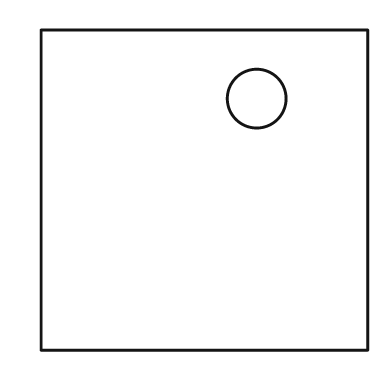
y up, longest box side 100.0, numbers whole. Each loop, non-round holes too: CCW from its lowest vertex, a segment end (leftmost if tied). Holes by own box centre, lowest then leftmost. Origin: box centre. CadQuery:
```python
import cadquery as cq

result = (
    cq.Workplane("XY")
    .moveTo(-50.0, -49.0)
    .lineTo(50.0, -49.0)
    .lineTo(50.0, 49.0)
    .lineTo(-50.0, 49.0)
    .close()
    .moveTo(16.0, 28.0)
    .circle(9.0)
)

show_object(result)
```